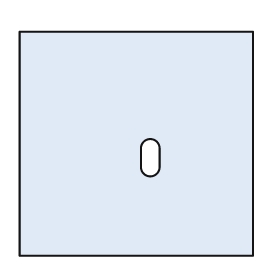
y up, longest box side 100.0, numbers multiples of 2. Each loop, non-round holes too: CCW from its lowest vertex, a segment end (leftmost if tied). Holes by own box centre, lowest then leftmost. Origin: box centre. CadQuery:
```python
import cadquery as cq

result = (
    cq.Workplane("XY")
    .moveTo(-50.0, -48.0)
    .lineTo(50.0, -48.0)
    .lineTo(50.0, 48.0)
    .lineTo(-50.0, 48.0)
    .close()
    .moveTo(2.0, -10.0)
    .threePointArc((6.0, -14.0), (10.0, -10.0))
    .lineTo(10.0, -2.0)
    .threePointArc((6.0, 2.0), (2.0, -2.0))
    .close()
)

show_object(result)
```